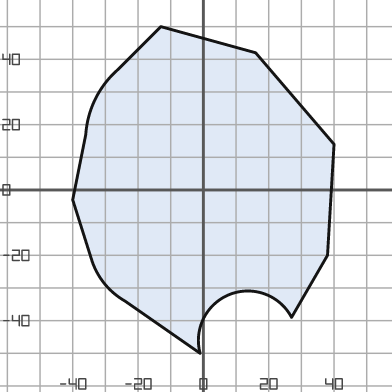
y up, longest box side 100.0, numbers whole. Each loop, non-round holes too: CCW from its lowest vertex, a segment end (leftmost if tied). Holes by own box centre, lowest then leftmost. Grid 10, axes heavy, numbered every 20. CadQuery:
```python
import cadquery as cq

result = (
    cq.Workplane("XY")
    .moveTo(-1.0, -50.0)
    .threePointArc((8.0, -32.0), (27.0, -39.0))
    .lineTo(38.0, -20.0)
    .lineTo(40.0, 14.0)
    .lineTo(16.0, 42.0)
    .lineTo(-13.0, 50.0)
    .lineTo(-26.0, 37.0)
    .threePointArc((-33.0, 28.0), (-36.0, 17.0))
    .lineTo(-40.0, -3.0)
    .lineTo(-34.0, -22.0)
    .threePointArc((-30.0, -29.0), (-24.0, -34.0))
    .close()
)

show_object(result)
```